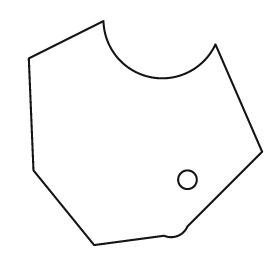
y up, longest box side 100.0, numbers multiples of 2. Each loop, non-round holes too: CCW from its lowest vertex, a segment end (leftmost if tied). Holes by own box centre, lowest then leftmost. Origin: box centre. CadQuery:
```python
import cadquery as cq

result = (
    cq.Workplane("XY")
    .moveTo(-22.0, -48.0)
    .lineTo(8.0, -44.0)
    .threePointArc((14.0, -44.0), (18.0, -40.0))
    .lineTo(50.0, -8.0)
    .lineTo(30.0, 38.0)
    .threePointArc((2.0, 24.0), (-18.0, 48.0))
    .lineTo(-50.0, 32.0)
    .lineTo(-48.0, -16.0)
    .close()
    .moveTo(18.0, -20.0)
    .circle(4.0)
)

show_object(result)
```